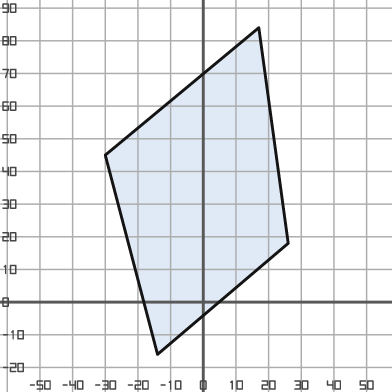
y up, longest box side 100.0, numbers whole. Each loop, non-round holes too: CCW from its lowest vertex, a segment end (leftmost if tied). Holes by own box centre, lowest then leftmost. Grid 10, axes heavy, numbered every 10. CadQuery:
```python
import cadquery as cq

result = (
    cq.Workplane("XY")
    .moveTo(-14.0, -16.0)
    .lineTo(26.0, 18.0)
    .lineTo(17.0, 84.0)
    .lineTo(-30.0, 45.0)
    .close()
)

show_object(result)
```